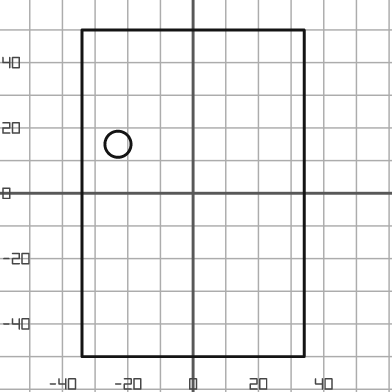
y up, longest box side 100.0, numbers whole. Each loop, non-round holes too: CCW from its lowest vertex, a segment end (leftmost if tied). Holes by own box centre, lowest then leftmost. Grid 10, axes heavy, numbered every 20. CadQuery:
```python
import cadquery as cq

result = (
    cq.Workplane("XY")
    .moveTo(-34.0, -50.0)
    .lineTo(34.0, -50.0)
    .lineTo(34.0, 50.0)
    .lineTo(-34.0, 50.0)
    .close()
    .moveTo(-23.0, 15.0)
    .circle(4.0)
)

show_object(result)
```